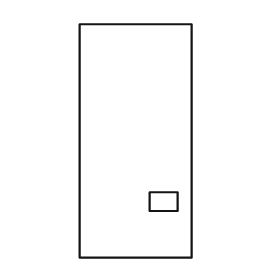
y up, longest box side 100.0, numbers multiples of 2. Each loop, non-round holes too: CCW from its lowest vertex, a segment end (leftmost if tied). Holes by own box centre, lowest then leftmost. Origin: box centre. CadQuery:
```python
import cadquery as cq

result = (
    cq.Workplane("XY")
    .moveTo(-24.0, -50.0)
    .lineTo(24.0, -50.0)
    .lineTo(24.0, 50.0)
    .lineTo(-24.0, 50.0)
    .close()
    .moveTo(6.0, -30.0)
    .lineTo(18.0, -30.0)
    .lineTo(18.0, -22.0)
    .lineTo(6.0, -22.0)
    .close()
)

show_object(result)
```